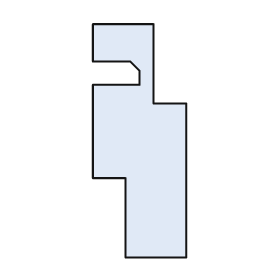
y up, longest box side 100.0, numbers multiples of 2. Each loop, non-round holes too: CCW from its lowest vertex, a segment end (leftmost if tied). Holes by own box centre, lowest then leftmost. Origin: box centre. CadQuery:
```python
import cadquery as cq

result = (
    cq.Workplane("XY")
    .moveTo(-6.0, -50.0)
    .lineTo(20.0, -50.0)
    .lineTo(20.0, 16.0)
    .lineTo(6.0, 16.0)
    .lineTo(6.0, 50.0)
    .lineTo(-20.0, 50.0)
    .lineTo(-20.0, 34.0)
    .lineTo(-4.0, 34.0)
    .lineTo(0.0, 30.0)
    .lineTo(0.0, 24.0)
    .lineTo(-20.0, 24.0)
    .lineTo(-20.0, -16.0)
    .lineTo(-6.0, -16.0)
    .close()
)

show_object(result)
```